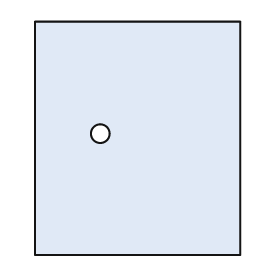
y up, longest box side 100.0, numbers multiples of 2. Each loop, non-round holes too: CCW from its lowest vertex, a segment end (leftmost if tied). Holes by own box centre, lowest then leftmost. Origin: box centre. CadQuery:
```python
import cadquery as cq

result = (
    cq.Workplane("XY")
    .moveTo(-44.0, -50.0)
    .lineTo(44.0, -50.0)
    .lineTo(44.0, 50.0)
    .lineTo(-44.0, 50.0)
    .close()
    .moveTo(-16.0, 2.0)
    .circle(4.0)
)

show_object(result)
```